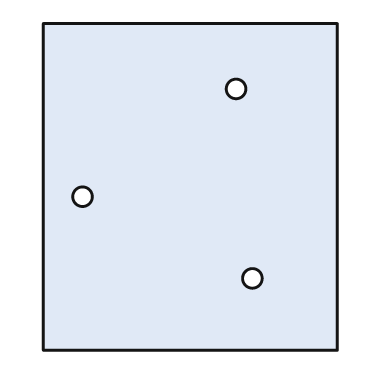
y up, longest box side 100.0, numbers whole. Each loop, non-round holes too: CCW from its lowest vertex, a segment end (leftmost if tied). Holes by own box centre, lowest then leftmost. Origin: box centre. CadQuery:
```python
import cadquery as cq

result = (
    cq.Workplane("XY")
    .moveTo(-45.0, -50.0)
    .lineTo(45.0, -50.0)
    .lineTo(45.0, 50.0)
    .lineTo(-45.0, 50.0)
    .close()
    .moveTo(19.0, -28.0)
    .circle(3.0)
    .moveTo(-33.0, -3.0)
    .circle(3.0)
    .moveTo(14.0, 30.0)
    .circle(3.0)
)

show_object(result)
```